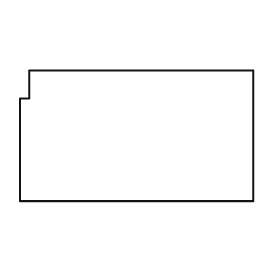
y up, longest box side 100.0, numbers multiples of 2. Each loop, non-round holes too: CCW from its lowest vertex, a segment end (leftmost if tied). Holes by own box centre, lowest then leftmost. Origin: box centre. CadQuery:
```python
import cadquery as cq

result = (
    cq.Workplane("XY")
    .moveTo(-50.0, -28.0)
    .lineTo(50.0, -28.0)
    .lineTo(50.0, 28.0)
    .lineTo(-46.0, 28.0)
    .lineTo(-46.0, 16.0)
    .lineTo(-50.0, 16.0)
    .close()
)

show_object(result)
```